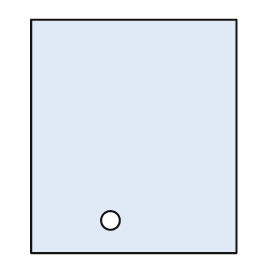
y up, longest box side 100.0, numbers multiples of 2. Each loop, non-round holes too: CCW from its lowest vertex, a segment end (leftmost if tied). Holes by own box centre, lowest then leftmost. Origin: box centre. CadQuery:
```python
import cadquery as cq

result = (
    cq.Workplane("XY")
    .moveTo(-44.0, -50.0)
    .lineTo(44.0, -50.0)
    .lineTo(44.0, 50.0)
    .lineTo(-44.0, 50.0)
    .close()
    .moveTo(-10.0, -36.0)
    .circle(4.0)
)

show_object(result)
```